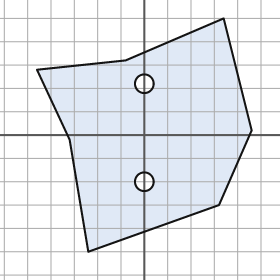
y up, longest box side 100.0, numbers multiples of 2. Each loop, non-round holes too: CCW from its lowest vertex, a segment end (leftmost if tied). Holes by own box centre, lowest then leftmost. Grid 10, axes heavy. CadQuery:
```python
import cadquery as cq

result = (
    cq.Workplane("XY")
    .moveTo(-24.0, -50.0)
    .lineTo(32.0, -30.0)
    .lineTo(46.0, 2.0)
    .lineTo(34.0, 50.0)
    .lineTo(-8.0, 32.0)
    .lineTo(-46.0, 28.0)
    .lineTo(-32.0, -2.0)
    .close()
    .moveTo(0.0, -20.0)
    .circle(4.0)
    .moveTo(0.0, 22.0)
    .circle(4.0)
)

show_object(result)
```